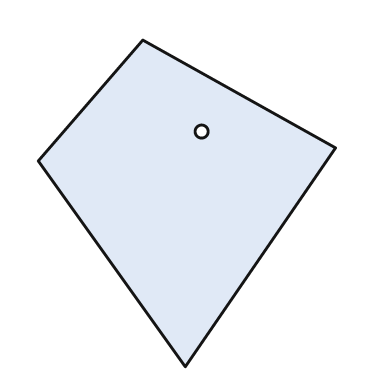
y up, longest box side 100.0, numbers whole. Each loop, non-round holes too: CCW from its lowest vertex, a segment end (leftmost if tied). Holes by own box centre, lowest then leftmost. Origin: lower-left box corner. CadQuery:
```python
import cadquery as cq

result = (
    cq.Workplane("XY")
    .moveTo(45.0, 0.0)
    .lineTo(91.0, 67.0)
    .lineTo(32.0, 100.0)
    .lineTo(0.0, 63.0)
    .close()
    .moveTo(50.0, 72.0)
    .circle(2.0)
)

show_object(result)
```